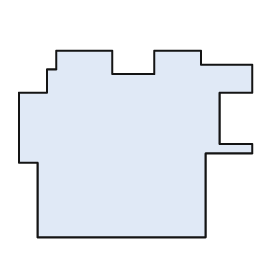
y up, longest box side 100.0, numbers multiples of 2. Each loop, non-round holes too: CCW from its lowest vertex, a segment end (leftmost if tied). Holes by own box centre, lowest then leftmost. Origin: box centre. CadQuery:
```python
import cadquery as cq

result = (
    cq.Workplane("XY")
    .moveTo(-42.0, -40.0)
    .lineTo(30.0, -40.0)
    .lineTo(30.0, -4.0)
    .lineTo(50.0, -4.0)
    .lineTo(50.0, 0.0)
    .lineTo(36.0, 0.0)
    .lineTo(36.0, 22.0)
    .lineTo(50.0, 22.0)
    .lineTo(50.0, 34.0)
    .lineTo(28.0, 34.0)
    .lineTo(28.0, 40.0)
    .lineTo(8.0, 40.0)
    .lineTo(8.0, 30.0)
    .lineTo(-10.0, 30.0)
    .lineTo(-10.0, 40.0)
    .lineTo(-34.0, 40.0)
    .lineTo(-34.0, 32.0)
    .lineTo(-38.0, 32.0)
    .lineTo(-38.0, 22.0)
    .lineTo(-50.0, 22.0)
    .lineTo(-50.0, -8.0)
    .lineTo(-42.0, -8.0)
    .close()
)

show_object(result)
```